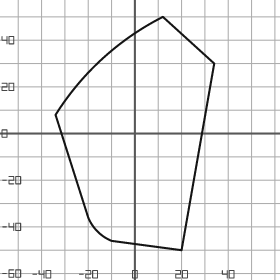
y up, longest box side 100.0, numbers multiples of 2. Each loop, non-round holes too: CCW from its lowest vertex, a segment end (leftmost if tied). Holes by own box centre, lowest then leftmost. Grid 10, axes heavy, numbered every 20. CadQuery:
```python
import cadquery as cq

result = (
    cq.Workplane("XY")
    .moveTo(20.0, -50.0)
    .lineTo(34.0, 30.0)
    .lineTo(12.0, 50.0)
    .threePointArc((-14.0, 32.0), (-34.0, 8.0))
    .lineTo(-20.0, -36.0)
    .threePointArc((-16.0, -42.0), (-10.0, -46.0))
    .close()
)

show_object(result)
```